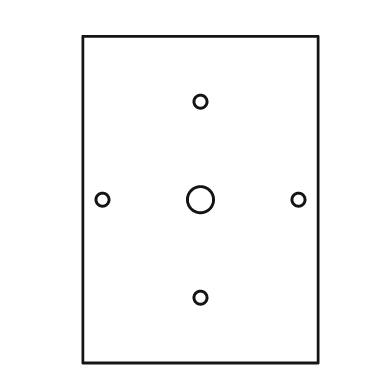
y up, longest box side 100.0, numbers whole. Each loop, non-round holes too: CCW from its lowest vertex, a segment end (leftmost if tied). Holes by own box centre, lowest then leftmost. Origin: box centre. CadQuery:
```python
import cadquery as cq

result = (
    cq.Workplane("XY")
    .moveTo(-36.0, -50.0)
    .lineTo(36.0, -50.0)
    .lineTo(36.0, 50.0)
    .lineTo(-36.0, 50.0)
    .close()
    .moveTo(0.0, -30.0)
    .circle(2.0)
    .moveTo(-30.0, 0.0)
    .circle(2.0)
    .moveTo(0.0, 0.0)
    .circle(4.0)
    .moveTo(30.0, 0.0)
    .circle(2.0)
    .moveTo(0.0, 30.0)
    .circle(2.0)
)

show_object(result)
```